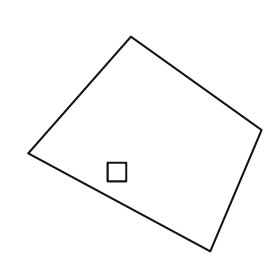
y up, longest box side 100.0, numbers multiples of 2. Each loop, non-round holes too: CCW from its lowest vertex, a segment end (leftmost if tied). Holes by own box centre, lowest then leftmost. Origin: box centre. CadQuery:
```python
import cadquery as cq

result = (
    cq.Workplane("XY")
    .moveTo(28.0, -46.0)
    .lineTo(50.0, 6.0)
    .lineTo(-6.0, 46.0)
    .lineTo(-50.0, -4.0)
    .close()
    .moveTo(-16.0, -16.0)
    .lineTo(-8.0, -16.0)
    .lineTo(-8.0, -8.0)
    .lineTo(-16.0, -8.0)
    .close()
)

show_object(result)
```